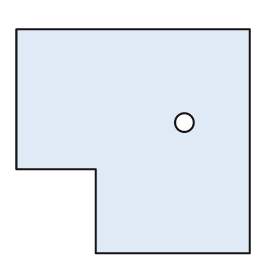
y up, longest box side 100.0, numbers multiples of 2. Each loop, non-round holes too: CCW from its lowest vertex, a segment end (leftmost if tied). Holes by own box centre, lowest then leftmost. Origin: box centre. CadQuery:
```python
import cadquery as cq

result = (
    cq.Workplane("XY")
    .moveTo(-16.0, -48.0)
    .lineTo(50.0, -48.0)
    .lineTo(50.0, 48.0)
    .lineTo(-50.0, 48.0)
    .lineTo(-50.0, -12.0)
    .lineTo(-16.0, -12.0)
    .close()
    .moveTo(22.0, 8.0)
    .circle(4.0)
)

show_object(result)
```